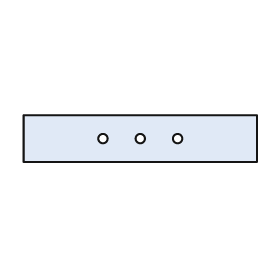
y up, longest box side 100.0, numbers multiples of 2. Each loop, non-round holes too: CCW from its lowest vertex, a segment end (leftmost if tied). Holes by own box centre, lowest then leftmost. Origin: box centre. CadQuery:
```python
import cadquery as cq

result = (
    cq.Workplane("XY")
    .moveTo(-50.0, -10.0)
    .lineTo(50.0, -10.0)
    .lineTo(50.0, 10.0)
    .lineTo(-50.0, 10.0)
    .close()
    .moveTo(-16.0, 0.0)
    .circle(2.0)
    .moveTo(0.0, 0.0)
    .circle(2.0)
    .moveTo(16.0, 0.0)
    .circle(2.0)
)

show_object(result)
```